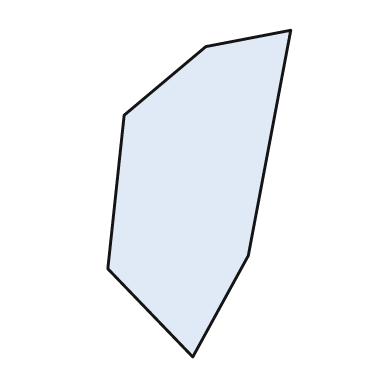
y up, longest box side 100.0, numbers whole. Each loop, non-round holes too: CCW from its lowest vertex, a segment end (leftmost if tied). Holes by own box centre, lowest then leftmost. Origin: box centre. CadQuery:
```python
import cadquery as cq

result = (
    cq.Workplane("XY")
    .moveTo(-2.0, -50.0)
    .lineTo(15.0, -19.0)
    .lineTo(28.0, 50.0)
    .lineTo(2.0, 45.0)
    .lineTo(-23.0, 24.0)
    .lineTo(-28.0, -23.0)
    .close()
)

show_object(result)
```